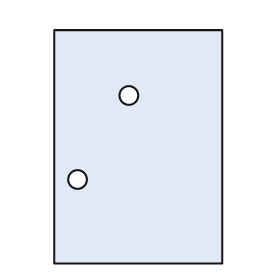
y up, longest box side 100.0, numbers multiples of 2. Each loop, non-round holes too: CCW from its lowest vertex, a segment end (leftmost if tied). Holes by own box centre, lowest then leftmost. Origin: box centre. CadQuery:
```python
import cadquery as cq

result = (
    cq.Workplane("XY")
    .moveTo(-36.0, -50.0)
    .lineTo(36.0, -50.0)
    .lineTo(36.0, 50.0)
    .lineTo(-36.0, 50.0)
    .close()
    .moveTo(-26.0, -14.0)
    .circle(4.0)
    .moveTo(-4.0, 22.0)
    .circle(4.0)
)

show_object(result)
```